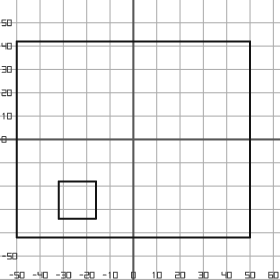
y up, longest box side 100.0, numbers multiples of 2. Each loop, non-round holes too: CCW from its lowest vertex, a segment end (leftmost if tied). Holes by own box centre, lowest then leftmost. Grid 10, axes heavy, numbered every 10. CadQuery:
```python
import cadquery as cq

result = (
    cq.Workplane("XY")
    .moveTo(-50.0, -42.0)
    .lineTo(50.0, -42.0)
    .lineTo(50.0, 42.0)
    .lineTo(-50.0, 42.0)
    .close()
    .moveTo(-32.0, -34.0)
    .lineTo(-16.0, -34.0)
    .lineTo(-16.0, -18.0)
    .lineTo(-32.0, -18.0)
    .close()
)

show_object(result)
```